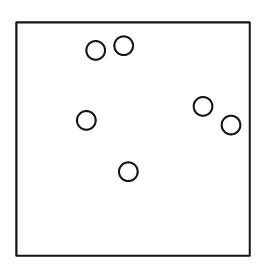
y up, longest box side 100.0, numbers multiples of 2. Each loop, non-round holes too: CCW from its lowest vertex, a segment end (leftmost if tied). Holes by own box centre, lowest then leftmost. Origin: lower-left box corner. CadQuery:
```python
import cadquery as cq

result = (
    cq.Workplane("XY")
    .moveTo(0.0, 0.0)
    .lineTo(100.0, 0.0)
    .lineTo(100.0, 100.0)
    .lineTo(0.0, 100.0)
    .close()
    .moveTo(48.0, 36.0)
    .circle(4.0)
    .moveTo(92.0, 56.0)
    .circle(4.0)
    .moveTo(30.0, 58.0)
    .circle(4.0)
    .moveTo(80.0, 64.0)
    .circle(4.0)
    .moveTo(34.0, 88.0)
    .circle(4.0)
    .moveTo(46.0, 90.0)
    .circle(4.0)
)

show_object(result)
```